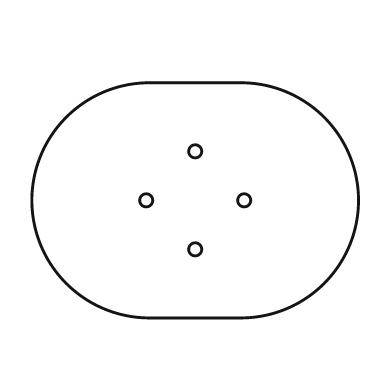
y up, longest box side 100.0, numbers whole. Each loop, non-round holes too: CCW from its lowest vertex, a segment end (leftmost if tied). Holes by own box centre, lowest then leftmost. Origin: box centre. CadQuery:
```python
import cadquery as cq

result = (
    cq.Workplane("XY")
    .moveTo(-14.0, -36.0)
    .lineTo(14.0, -36.0)
    .threePointArc((50.0, 0.0), (14.0, 36.0))
    .lineTo(-14.0, 36.0)
    .threePointArc((-50.0, 0.0), (-14.0, -36.0))
    .close()
    .moveTo(0.0, -15.0)
    .circle(2.0)
    .moveTo(-15.0, 0.0)
    .circle(2.0)
    .moveTo(15.0, 0.0)
    .circle(2.0)
    .moveTo(0.0, 15.0)
    .circle(2.0)
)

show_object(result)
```